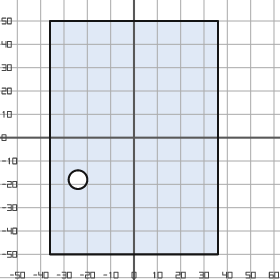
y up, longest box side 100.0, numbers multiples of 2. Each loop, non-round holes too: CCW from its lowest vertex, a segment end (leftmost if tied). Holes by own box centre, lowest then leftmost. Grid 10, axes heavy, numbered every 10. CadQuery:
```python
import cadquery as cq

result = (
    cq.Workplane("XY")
    .moveTo(-36.0, -50.0)
    .lineTo(36.0, -50.0)
    .lineTo(36.0, 50.0)
    .lineTo(-36.0, 50.0)
    .close()
    .moveTo(-24.0, -18.0)
    .circle(4.0)
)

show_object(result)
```